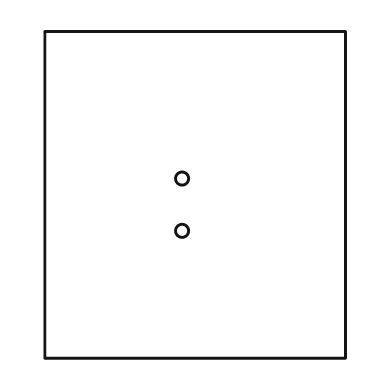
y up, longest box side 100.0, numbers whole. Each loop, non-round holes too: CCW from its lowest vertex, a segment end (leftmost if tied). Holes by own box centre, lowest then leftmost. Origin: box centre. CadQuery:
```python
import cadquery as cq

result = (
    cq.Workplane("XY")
    .moveTo(-46.0, -50.0)
    .lineTo(46.0, -50.0)
    .lineTo(46.0, 50.0)
    .lineTo(-46.0, 50.0)
    .close()
    .moveTo(-4.0, -11.0)
    .circle(2.0)
    .moveTo(-4.0, 5.0)
    .circle(2.0)
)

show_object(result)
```